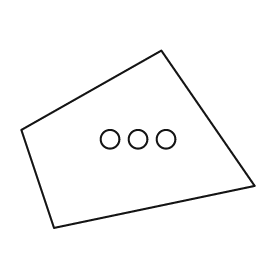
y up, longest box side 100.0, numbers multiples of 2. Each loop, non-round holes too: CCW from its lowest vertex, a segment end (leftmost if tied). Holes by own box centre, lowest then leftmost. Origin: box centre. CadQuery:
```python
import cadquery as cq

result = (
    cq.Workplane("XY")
    .moveTo(-36.0, -38.0)
    .lineTo(50.0, -20.0)
    .lineTo(10.0, 38.0)
    .lineTo(-50.0, 4.0)
    .close()
    .moveTo(-12.0, 0.0)
    .circle(4.0)
    .moveTo(0.0, 0.0)
    .circle(4.0)
    .moveTo(12.0, 0.0)
    .circle(4.0)
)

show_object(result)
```